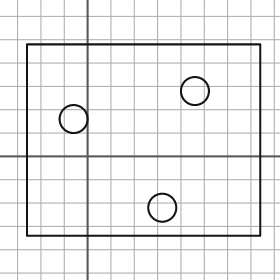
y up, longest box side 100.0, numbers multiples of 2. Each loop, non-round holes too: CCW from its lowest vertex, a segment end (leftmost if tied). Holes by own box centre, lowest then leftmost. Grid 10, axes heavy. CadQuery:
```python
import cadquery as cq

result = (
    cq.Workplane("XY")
    .moveTo(-26.0, -34.0)
    .lineTo(74.0, -34.0)
    .lineTo(74.0, 48.0)
    .lineTo(-26.0, 48.0)
    .close()
    .moveTo(32.0, -22.0)
    .circle(6.0)
    .moveTo(-6.0, 16.0)
    .circle(6.0)
    .moveTo(46.0, 28.0)
    .circle(6.0)
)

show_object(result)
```